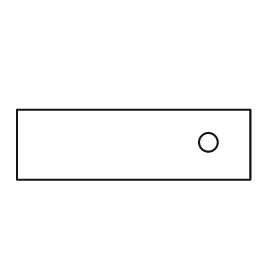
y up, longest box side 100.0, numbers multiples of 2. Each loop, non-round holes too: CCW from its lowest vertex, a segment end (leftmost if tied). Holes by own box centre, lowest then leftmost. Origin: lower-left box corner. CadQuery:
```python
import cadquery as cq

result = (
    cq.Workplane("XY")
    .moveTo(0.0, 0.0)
    .lineTo(100.0, 0.0)
    .lineTo(100.0, 30.0)
    .lineTo(0.0, 30.0)
    .close()
    .moveTo(82.0, 16.0)
    .circle(4.0)
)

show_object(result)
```